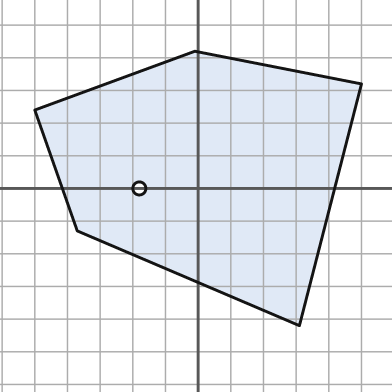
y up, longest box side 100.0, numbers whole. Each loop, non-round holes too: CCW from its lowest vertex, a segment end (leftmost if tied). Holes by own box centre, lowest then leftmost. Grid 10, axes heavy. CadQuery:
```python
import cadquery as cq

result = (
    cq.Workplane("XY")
    .moveTo(31.0, -42.0)
    .lineTo(50.0, 32.0)
    .lineTo(-1.0, 42.0)
    .lineTo(-50.0, 24.0)
    .lineTo(-37.0, -13.0)
    .close()
    .moveTo(-18.0, 0.0)
    .circle(2.0)
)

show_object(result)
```